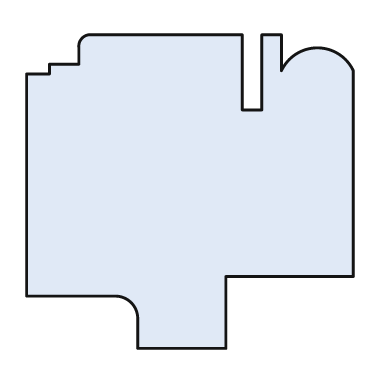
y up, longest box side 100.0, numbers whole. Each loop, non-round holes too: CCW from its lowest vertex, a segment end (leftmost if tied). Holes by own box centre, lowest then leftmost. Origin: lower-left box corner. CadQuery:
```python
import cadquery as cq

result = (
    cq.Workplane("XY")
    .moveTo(34.0, 0.0)
    .lineTo(61.0, 0.0)
    .lineTo(61.0, 22.0)
    .lineTo(100.0, 22.0)
    .lineTo(100.0, 85.0)
    .threePointArc((89.0, 92.0), (78.0, 85.0))
    .lineTo(78.0, 96.0)
    .lineTo(72.0, 96.0)
    .lineTo(72.0, 73.0)
    .lineTo(66.0, 73.0)
    .lineTo(66.0, 96.0)
    .lineTo(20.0, 96.0)
    .threePointArc((17.0, 95.0), (16.0, 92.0))
    .lineTo(16.0, 87.0)
    .lineTo(7.0, 87.0)
    .lineTo(7.0, 84.0)
    .lineTo(0.0, 84.0)
    .lineTo(0.0, 16.0)
    .lineTo(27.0, 16.0)
    .threePointArc((32.0, 14.0), (34.0, 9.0))
    .close()
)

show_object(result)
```